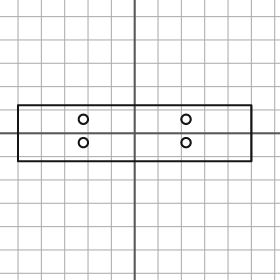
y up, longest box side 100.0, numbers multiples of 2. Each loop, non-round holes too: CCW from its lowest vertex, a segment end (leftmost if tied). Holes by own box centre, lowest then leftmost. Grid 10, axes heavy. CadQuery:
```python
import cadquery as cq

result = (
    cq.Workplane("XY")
    .moveTo(-50.0, -12.0)
    .lineTo(50.0, -12.0)
    .lineTo(50.0, 12.0)
    .lineTo(-50.0, 12.0)
    .close()
    .moveTo(-22.0, -4.0)
    .circle(2.0)
    .moveTo(22.0, -4.0)
    .circle(2.0)
    .moveTo(-22.0, 6.0)
    .circle(2.0)
    .moveTo(22.0, 6.0)
    .circle(2.0)
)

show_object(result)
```